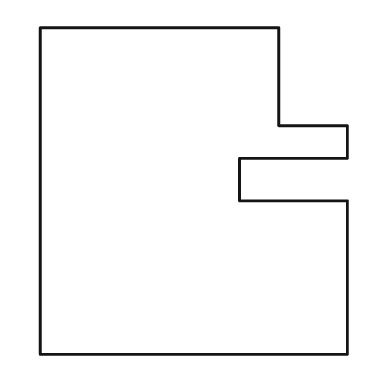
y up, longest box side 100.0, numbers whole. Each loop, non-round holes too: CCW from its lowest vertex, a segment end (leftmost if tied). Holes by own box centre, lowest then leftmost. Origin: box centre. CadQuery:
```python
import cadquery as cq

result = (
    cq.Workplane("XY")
    .moveTo(-47.0, -50.0)
    .lineTo(47.0, -50.0)
    .lineTo(47.0, -3.0)
    .lineTo(14.0, -3.0)
    .lineTo(14.0, 10.0)
    .lineTo(47.0, 10.0)
    .lineTo(47.0, 20.0)
    .lineTo(26.0, 20.0)
    .lineTo(26.0, 50.0)
    .lineTo(-47.0, 50.0)
    .close()
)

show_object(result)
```